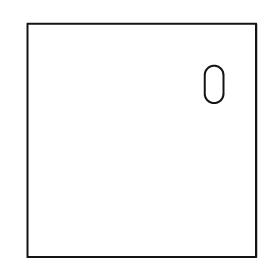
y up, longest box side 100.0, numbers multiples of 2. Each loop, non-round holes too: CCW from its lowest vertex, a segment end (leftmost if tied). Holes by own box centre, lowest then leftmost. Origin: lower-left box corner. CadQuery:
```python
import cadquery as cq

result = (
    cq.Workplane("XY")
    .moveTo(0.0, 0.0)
    .lineTo(98.0, 0.0)
    .lineTo(98.0, 100.0)
    .lineTo(0.0, 100.0)
    .close()
    .moveTo(76.0, 70.0)
    .threePointArc((80.0, 66.0), (84.0, 70.0))
    .lineTo(84.0, 78.0)
    .threePointArc((80.0, 82.0), (76.0, 78.0))
    .close()
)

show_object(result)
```